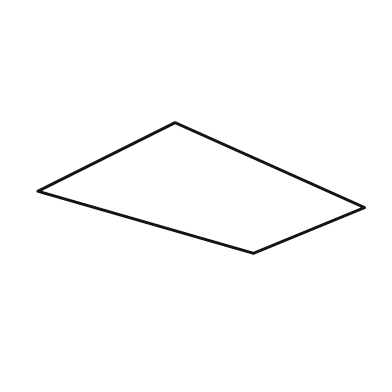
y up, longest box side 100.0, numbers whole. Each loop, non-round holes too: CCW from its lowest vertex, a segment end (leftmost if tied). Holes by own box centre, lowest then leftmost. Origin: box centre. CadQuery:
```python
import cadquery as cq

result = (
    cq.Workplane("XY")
    .moveTo(16.0, -20.0)
    .lineTo(50.0, -6.0)
    .lineTo(-8.0, 20.0)
    .lineTo(-50.0, -1.0)
    .close()
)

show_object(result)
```